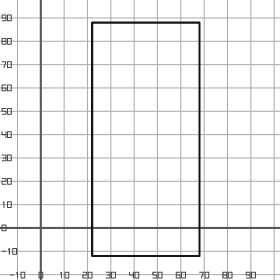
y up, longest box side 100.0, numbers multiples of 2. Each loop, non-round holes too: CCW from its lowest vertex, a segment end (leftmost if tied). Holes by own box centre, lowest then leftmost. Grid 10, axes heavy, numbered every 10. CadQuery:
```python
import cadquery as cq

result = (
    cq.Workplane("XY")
    .moveTo(22.0, -12.0)
    .lineTo(68.0, -12.0)
    .lineTo(68.0, 88.0)
    .lineTo(22.0, 88.0)
    .close()
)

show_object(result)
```